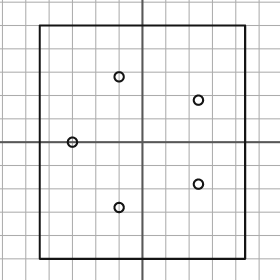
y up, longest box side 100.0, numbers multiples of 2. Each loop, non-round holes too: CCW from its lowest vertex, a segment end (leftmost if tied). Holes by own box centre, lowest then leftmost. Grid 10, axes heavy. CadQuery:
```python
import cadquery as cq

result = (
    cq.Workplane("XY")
    .moveTo(-44.0, -50.0)
    .lineTo(44.0, -50.0)
    .lineTo(44.0, 50.0)
    .lineTo(-44.0, 50.0)
    .close()
    .moveTo(-10.0, -28.0)
    .circle(2.0)
    .moveTo(24.0, -18.0)
    .circle(2.0)
    .moveTo(-30.0, 0.0)
    .circle(2.0)
    .moveTo(24.0, 18.0)
    .circle(2.0)
    .moveTo(-10.0, 28.0)
    .circle(2.0)
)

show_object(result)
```